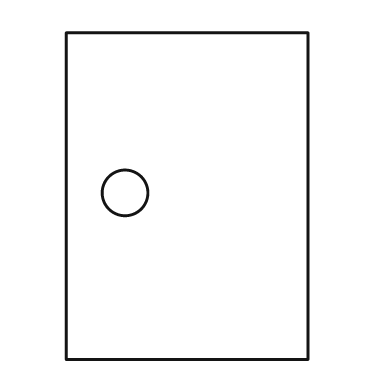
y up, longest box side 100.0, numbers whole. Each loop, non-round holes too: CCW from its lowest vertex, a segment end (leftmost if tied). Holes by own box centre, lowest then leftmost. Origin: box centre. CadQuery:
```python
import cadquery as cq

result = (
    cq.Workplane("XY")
    .moveTo(-37.0, -50.0)
    .lineTo(37.0, -50.0)
    .lineTo(37.0, 50.0)
    .lineTo(-37.0, 50.0)
    .close()
    .moveTo(-19.0, 1.0)
    .circle(7.0)
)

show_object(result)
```